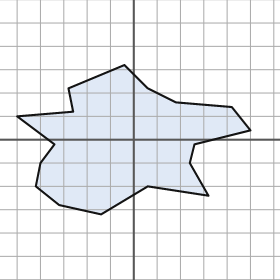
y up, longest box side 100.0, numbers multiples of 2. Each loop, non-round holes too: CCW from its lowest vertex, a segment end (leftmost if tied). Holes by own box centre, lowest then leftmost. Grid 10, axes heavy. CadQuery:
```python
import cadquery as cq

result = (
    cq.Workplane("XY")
    .moveTo(-14.0, -32.0)
    .lineTo(6.0, -20.0)
    .lineTo(32.0, -24.0)
    .lineTo(24.0, -10.0)
    .lineTo(26.0, -2.0)
    .lineTo(50.0, 4.0)
    .lineTo(42.0, 14.0)
    .lineTo(18.0, 16.0)
    .lineTo(6.0, 22.0)
    .lineTo(-4.0, 32.0)
    .lineTo(-28.0, 22.0)
    .lineTo(-26.0, 12.0)
    .lineTo(-50.0, 10.0)
    .lineTo(-34.0, -2.0)
    .lineTo(-40.0, -10.0)
    .lineTo(-42.0, -20.0)
    .lineTo(-32.0, -28.0)
    .close()
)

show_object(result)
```